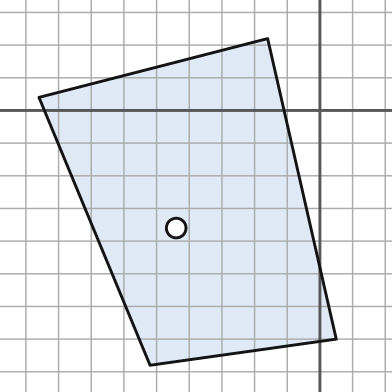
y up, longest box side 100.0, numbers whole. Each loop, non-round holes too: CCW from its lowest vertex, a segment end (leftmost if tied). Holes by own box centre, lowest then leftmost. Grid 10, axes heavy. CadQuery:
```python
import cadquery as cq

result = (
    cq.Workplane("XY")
    .moveTo(-52.0, -78.0)
    .lineTo(5.0, -70.0)
    .lineTo(-16.0, 22.0)
    .lineTo(-86.0, 4.0)
    .close()
    .moveTo(-44.0, -36.0)
    .circle(3.0)
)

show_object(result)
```